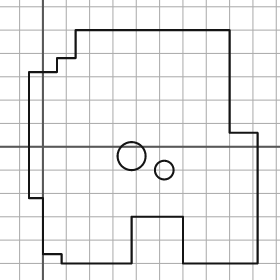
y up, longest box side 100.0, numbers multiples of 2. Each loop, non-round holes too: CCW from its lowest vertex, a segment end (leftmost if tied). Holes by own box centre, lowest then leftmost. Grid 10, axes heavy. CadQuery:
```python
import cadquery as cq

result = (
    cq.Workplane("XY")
    .moveTo(8.0, -50.0)
    .lineTo(38.0, -50.0)
    .lineTo(38.0, -30.0)
    .lineTo(60.0, -30.0)
    .lineTo(60.0, -50.0)
    .lineTo(92.0, -50.0)
    .lineTo(92.0, 6.0)
    .lineTo(80.0, 6.0)
    .lineTo(80.0, 50.0)
    .lineTo(14.0, 50.0)
    .lineTo(14.0, 38.0)
    .lineTo(6.0, 38.0)
    .lineTo(6.0, 32.0)
    .lineTo(-6.0, 32.0)
    .lineTo(-6.0, -22.0)
    .lineTo(0.0, -22.0)
    .lineTo(0.0, -46.0)
    .lineTo(8.0, -46.0)
    .close()
    .moveTo(52.0, -10.0)
    .circle(4.0)
    .moveTo(38.0, -4.0)
    .circle(6.0)
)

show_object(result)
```